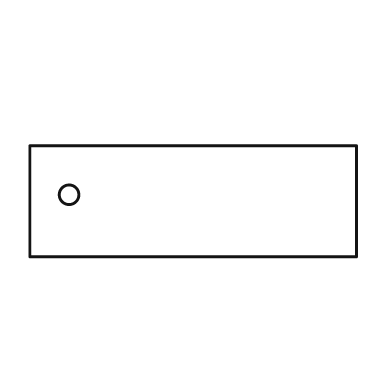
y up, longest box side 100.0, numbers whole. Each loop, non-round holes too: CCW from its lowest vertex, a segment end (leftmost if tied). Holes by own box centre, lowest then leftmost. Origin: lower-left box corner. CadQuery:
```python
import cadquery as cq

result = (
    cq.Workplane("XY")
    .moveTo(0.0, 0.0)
    .lineTo(100.0, 0.0)
    .lineTo(100.0, 34.0)
    .lineTo(0.0, 34.0)
    .close()
    .moveTo(12.0, 19.0)
    .circle(3.0)
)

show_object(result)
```